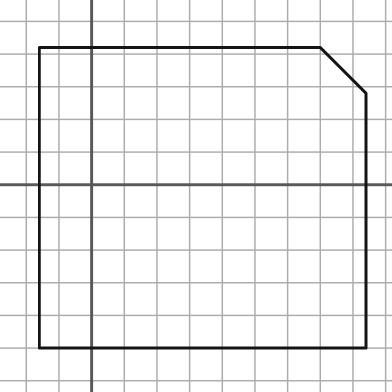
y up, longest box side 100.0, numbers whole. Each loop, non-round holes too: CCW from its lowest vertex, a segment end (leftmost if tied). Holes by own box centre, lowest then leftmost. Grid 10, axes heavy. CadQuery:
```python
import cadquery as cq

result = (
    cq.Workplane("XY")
    .moveTo(-16.0, -50.0)
    .lineTo(84.0, -50.0)
    .lineTo(84.0, 28.0)
    .lineTo(70.0, 42.0)
    .lineTo(-16.0, 42.0)
    .close()
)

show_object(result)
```